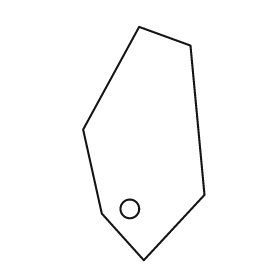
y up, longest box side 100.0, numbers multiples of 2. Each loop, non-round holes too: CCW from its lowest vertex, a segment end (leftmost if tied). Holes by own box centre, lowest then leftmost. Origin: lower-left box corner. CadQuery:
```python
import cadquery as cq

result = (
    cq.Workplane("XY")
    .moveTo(26.0, 0.0)
    .lineTo(52.0, 28.0)
    .lineTo(46.0, 92.0)
    .lineTo(24.0, 100.0)
    .lineTo(0.0, 56.0)
    .lineTo(8.0, 20.0)
    .close()
    .moveTo(20.0, 22.0)
    .circle(4.0)
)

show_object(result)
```